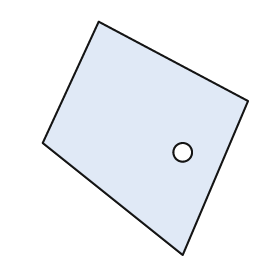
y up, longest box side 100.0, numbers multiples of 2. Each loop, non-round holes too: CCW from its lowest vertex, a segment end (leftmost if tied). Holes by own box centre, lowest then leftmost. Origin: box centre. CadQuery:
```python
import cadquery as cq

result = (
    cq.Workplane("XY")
    .moveTo(16.0, -50.0)
    .lineTo(44.0, 16.0)
    .lineTo(-20.0, 50.0)
    .lineTo(-44.0, -2.0)
    .close()
    .moveTo(16.0, -6.0)
    .circle(4.0)
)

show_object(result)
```